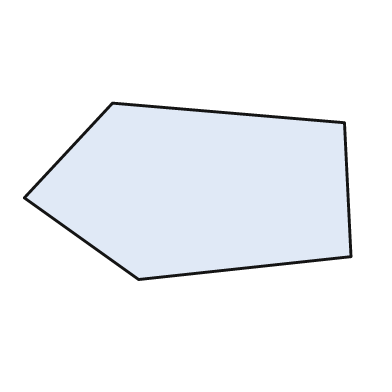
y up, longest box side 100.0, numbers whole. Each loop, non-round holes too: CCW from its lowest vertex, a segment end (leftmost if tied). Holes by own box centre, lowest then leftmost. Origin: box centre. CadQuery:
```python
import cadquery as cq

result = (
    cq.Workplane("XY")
    .moveTo(-15.0, -27.0)
    .lineTo(50.0, -20.0)
    .lineTo(48.0, 21.0)
    .lineTo(-23.0, 27.0)
    .lineTo(-50.0, -2.0)
    .close()
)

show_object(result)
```